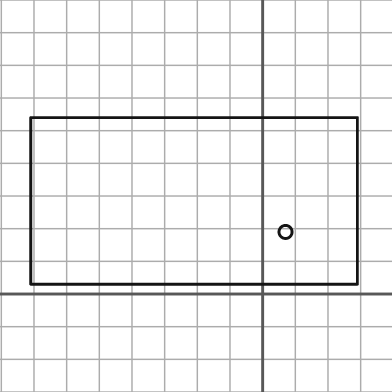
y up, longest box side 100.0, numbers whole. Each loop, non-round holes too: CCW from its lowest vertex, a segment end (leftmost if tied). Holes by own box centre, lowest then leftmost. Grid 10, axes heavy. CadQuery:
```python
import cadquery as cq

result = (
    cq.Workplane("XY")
    .moveTo(-71.0, 3.0)
    .lineTo(29.0, 3.0)
    .lineTo(29.0, 54.0)
    .lineTo(-71.0, 54.0)
    .close()
    .moveTo(7.0, 19.0)
    .circle(2.0)
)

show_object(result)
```